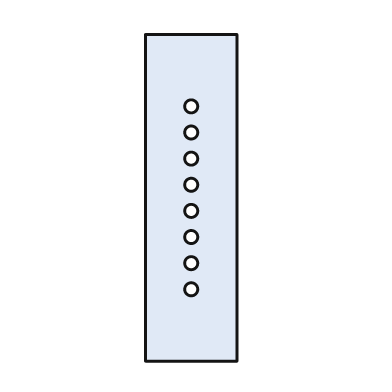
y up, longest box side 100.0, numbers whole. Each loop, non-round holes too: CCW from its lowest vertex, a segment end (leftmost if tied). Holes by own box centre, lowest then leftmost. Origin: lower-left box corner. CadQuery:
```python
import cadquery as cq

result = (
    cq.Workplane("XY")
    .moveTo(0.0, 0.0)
    .lineTo(28.0, 0.0)
    .lineTo(28.0, 100.0)
    .lineTo(0.0, 100.0)
    .close()
    .moveTo(14.0, 22.0)
    .circle(2.0)
    .moveTo(14.0, 30.0)
    .circle(2.0)
    .moveTo(14.0, 38.0)
    .circle(2.0)
    .moveTo(14.0, 46.0)
    .circle(2.0)
    .moveTo(14.0, 54.0)
    .circle(2.0)
    .moveTo(14.0, 62.0)
    .circle(2.0)
    .moveTo(14.0, 70.0)
    .circle(2.0)
    .moveTo(14.0, 78.0)
    .circle(2.0)
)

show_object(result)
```